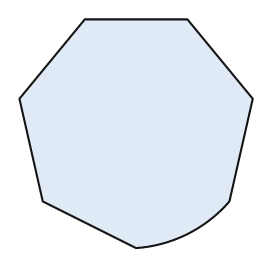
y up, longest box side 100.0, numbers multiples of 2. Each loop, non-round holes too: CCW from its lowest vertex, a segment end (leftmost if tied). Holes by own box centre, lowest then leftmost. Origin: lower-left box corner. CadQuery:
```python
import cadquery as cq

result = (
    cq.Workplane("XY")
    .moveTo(50.0, 0.0)
    .threePointArc((72.0, 6.0), (90.0, 20.0))
    .lineTo(100.0, 64.0)
    .lineTo(72.0, 98.0)
    .lineTo(28.0, 98.0)
    .lineTo(0.0, 64.0)
    .lineTo(10.0, 20.0)
    .close()
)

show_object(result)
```